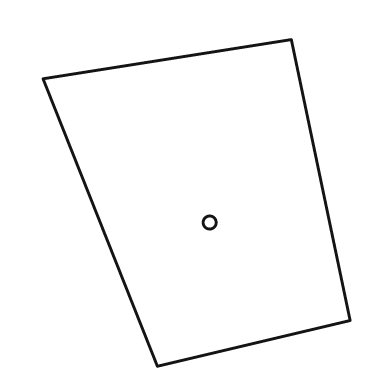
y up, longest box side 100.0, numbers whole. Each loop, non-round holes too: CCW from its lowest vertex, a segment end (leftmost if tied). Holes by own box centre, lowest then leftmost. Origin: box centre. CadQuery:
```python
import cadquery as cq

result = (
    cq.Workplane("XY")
    .moveTo(-12.0, -50.0)
    .lineTo(47.0, -36.0)
    .lineTo(29.0, 50.0)
    .lineTo(-47.0, 38.0)
    .close()
    .moveTo(4.0, -6.0)
    .circle(2.0)
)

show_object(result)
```